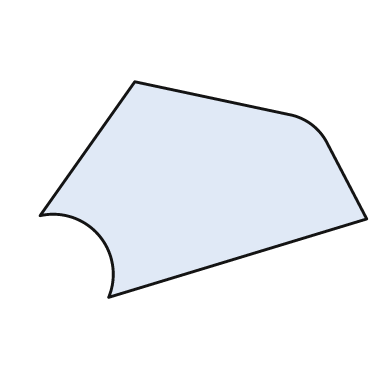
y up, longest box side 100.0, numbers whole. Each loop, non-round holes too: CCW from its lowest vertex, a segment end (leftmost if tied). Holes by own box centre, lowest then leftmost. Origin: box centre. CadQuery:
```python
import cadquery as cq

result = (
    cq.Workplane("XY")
    .moveTo(-29.0, -33.0)
    .lineTo(50.0, -9.0)
    .lineTo(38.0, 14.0)
    .threePointArc((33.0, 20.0), (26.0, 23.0))
    .lineTo(-21.0, 33.0)
    .lineTo(-50.0, -8.0)
    .threePointArc((-32.0, -14.0), (-29.0, -33.0))
    .close()
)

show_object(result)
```